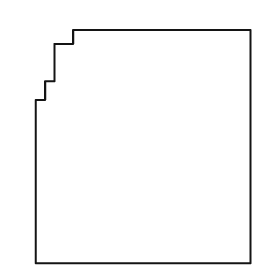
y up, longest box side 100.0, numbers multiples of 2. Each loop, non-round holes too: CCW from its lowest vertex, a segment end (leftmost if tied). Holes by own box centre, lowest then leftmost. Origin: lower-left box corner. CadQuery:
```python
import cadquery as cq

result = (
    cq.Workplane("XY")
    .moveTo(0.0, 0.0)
    .lineTo(92.0, 0.0)
    .lineTo(92.0, 100.0)
    .lineTo(16.0, 100.0)
    .lineTo(16.0, 94.0)
    .lineTo(8.0, 94.0)
    .lineTo(8.0, 78.0)
    .lineTo(4.0, 78.0)
    .lineTo(4.0, 70.0)
    .lineTo(0.0, 70.0)
    .close()
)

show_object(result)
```